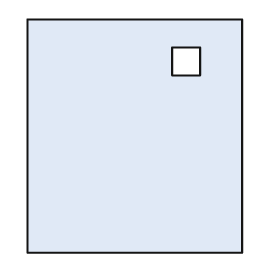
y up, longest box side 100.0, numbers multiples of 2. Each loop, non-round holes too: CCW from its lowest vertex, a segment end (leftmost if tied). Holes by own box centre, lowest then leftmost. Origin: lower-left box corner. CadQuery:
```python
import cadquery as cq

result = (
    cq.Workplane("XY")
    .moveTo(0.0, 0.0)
    .lineTo(92.0, 0.0)
    .lineTo(92.0, 100.0)
    .lineTo(0.0, 100.0)
    .close()
    .moveTo(62.0, 76.0)
    .lineTo(74.0, 76.0)
    .lineTo(74.0, 88.0)
    .lineTo(62.0, 88.0)
    .close()
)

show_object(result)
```